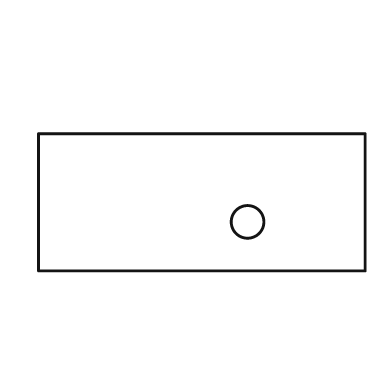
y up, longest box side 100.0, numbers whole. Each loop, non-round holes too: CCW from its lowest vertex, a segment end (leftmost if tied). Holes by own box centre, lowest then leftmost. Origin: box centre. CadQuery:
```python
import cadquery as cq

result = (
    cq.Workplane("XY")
    .moveTo(-50.0, -21.0)
    .lineTo(50.0, -21.0)
    .lineTo(50.0, 21.0)
    .lineTo(-50.0, 21.0)
    .close()
    .moveTo(14.0, -6.0)
    .circle(5.0)
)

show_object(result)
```